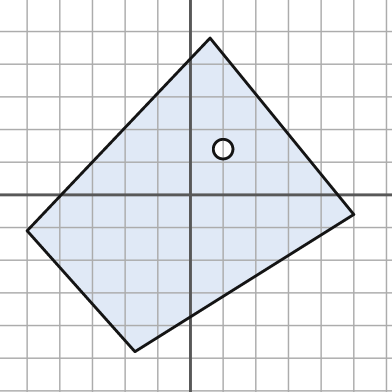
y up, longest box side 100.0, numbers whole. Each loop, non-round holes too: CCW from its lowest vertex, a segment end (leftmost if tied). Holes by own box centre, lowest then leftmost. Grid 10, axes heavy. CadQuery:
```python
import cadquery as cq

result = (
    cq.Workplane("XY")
    .moveTo(-17.0, -48.0)
    .lineTo(50.0, -6.0)
    .lineTo(6.0, 48.0)
    .lineTo(-50.0, -11.0)
    .close()
    .moveTo(10.0, 14.0)
    .circle(3.0)
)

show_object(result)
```